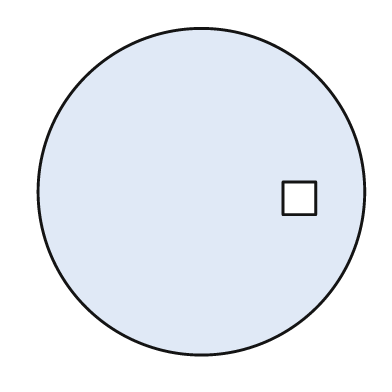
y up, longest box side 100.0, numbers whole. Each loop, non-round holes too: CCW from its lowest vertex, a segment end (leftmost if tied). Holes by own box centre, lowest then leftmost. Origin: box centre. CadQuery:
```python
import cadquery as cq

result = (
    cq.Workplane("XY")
    .moveTo(0.0, 0.0)
    .circle(50.0)
    .moveTo(25.0, -7.0)
    .lineTo(35.0, -7.0)
    .lineTo(35.0, 3.0)
    .lineTo(25.0, 3.0)
    .close()
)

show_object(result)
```